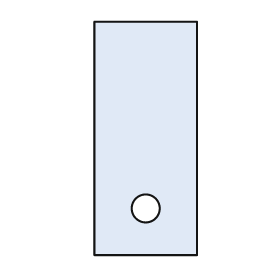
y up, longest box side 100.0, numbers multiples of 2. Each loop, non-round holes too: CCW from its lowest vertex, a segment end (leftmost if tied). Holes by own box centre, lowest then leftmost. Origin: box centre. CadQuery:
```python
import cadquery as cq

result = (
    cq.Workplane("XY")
    .moveTo(-22.0, -50.0)
    .lineTo(22.0, -50.0)
    .lineTo(22.0, 50.0)
    .lineTo(-22.0, 50.0)
    .close()
    .moveTo(0.0, -30.0)
    .circle(6.0)
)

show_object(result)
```